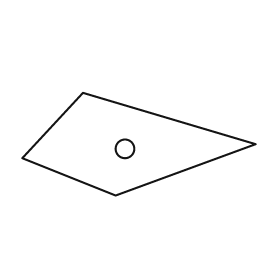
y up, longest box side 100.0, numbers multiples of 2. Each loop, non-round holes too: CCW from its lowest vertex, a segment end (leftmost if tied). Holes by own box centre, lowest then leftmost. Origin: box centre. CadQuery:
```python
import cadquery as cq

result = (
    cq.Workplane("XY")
    .moveTo(-10.0, -22.0)
    .lineTo(50.0, 0.0)
    .lineTo(-24.0, 22.0)
    .lineTo(-50.0, -6.0)
    .close()
    .moveTo(-6.0, -2.0)
    .circle(4.0)
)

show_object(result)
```